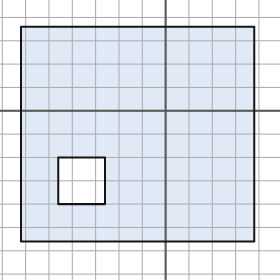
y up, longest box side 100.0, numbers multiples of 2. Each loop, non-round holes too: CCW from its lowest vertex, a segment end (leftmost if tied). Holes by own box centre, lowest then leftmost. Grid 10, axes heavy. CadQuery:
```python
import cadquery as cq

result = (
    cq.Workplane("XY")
    .moveTo(-62.0, -56.0)
    .lineTo(38.0, -56.0)
    .lineTo(38.0, 36.0)
    .lineTo(-62.0, 36.0)
    .close()
    .moveTo(-46.0, -40.0)
    .lineTo(-26.0, -40.0)
    .lineTo(-26.0, -20.0)
    .lineTo(-46.0, -20.0)
    .close()
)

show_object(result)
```